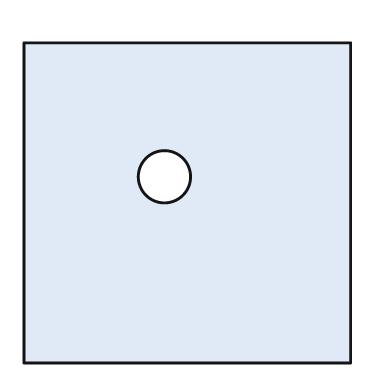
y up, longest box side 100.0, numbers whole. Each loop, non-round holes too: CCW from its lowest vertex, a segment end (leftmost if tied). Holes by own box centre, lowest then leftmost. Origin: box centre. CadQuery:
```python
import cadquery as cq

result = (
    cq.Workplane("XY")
    .moveTo(-50.0, -49.0)
    .lineTo(50.0, -49.0)
    .lineTo(50.0, 49.0)
    .lineTo(-50.0, 49.0)
    .close()
    .moveTo(-7.0, 8.0)
    .circle(8.0)
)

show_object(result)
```